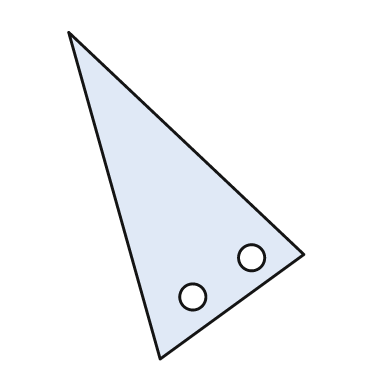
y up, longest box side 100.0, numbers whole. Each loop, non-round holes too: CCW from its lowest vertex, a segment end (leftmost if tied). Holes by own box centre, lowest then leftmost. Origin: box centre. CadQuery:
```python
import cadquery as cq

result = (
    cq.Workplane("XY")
    .moveTo(-8.0, -50.0)
    .lineTo(36.0, -18.0)
    .lineTo(-36.0, 50.0)
    .close()
    .moveTo(2.0, -31.0)
    .circle(4.0)
    .moveTo(20.0, -19.0)
    .circle(4.0)
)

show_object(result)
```